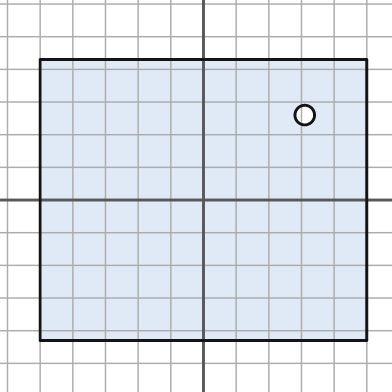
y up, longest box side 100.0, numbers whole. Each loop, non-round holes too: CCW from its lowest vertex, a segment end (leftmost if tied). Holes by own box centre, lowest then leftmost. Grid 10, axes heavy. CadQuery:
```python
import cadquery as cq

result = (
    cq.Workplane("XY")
    .moveTo(-50.0, -43.0)
    .lineTo(50.0, -43.0)
    .lineTo(50.0, 43.0)
    .lineTo(-50.0, 43.0)
    .close()
    .moveTo(31.0, 26.0)
    .circle(3.0)
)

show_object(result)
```